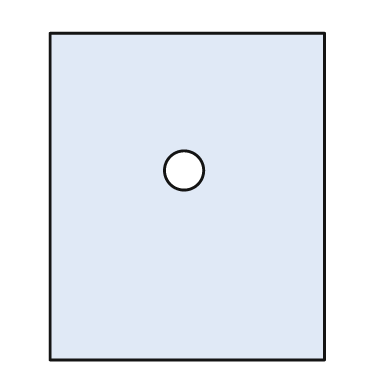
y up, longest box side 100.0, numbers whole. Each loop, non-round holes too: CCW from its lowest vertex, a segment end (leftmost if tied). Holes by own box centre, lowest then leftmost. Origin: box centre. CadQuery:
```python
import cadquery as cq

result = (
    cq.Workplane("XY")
    .moveTo(-42.0, -50.0)
    .lineTo(42.0, -50.0)
    .lineTo(42.0, 50.0)
    .lineTo(-42.0, 50.0)
    .close()
    .moveTo(-1.0, 8.0)
    .circle(6.0)
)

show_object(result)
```